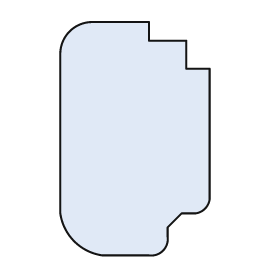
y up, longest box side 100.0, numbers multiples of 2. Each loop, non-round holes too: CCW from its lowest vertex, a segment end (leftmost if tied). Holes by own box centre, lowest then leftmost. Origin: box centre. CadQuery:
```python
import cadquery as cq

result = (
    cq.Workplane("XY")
    .moveTo(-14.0, -50.0)
    .lineTo(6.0, -50.0)
    .threePointArc((12.0, -48.0), (14.0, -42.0))
    .lineTo(14.0, -38.0)
    .lineTo(20.0, -32.0)
    .lineTo(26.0, -32.0)
    .threePointArc((30.0, -30.0), (32.0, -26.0))
    .lineTo(32.0, 30.0)
    .lineTo(22.0, 30.0)
    .lineTo(22.0, 42.0)
    .lineTo(6.0, 42.0)
    .lineTo(6.0, 50.0)
    .lineTo(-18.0, 50.0)
    .threePointArc((-28.0, 46.0), (-32.0, 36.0))
    .lineTo(-32.0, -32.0)
    .threePointArc((-26.0, -44.0), (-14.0, -50.0))
    .close()
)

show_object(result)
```